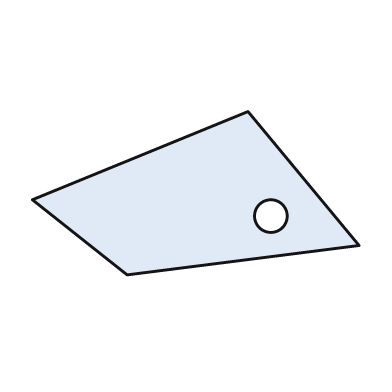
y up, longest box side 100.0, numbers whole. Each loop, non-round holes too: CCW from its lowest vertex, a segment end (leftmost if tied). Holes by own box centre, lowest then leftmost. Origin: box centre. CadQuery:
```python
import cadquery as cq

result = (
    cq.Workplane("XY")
    .moveTo(-21.0, -25.0)
    .lineTo(50.0, -16.0)
    .lineTo(16.0, 25.0)
    .lineTo(-50.0, -2.0)
    .close()
    .moveTo(23.0, -7.0)
    .circle(5.0)
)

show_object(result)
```